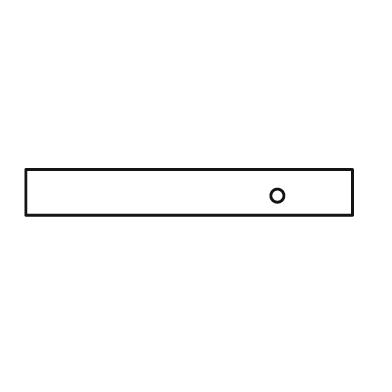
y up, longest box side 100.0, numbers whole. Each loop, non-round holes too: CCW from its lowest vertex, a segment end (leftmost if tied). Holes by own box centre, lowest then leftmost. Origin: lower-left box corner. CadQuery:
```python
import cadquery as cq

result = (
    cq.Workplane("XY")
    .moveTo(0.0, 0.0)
    .lineTo(100.0, 0.0)
    .lineTo(100.0, 14.0)
    .lineTo(0.0, 14.0)
    .close()
    .moveTo(77.0, 6.0)
    .circle(2.0)
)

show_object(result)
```